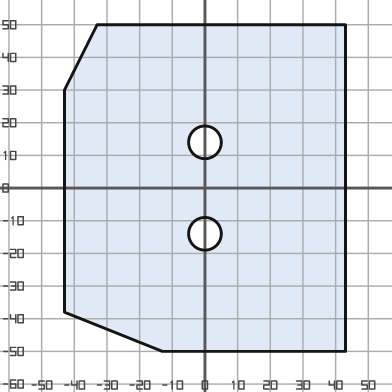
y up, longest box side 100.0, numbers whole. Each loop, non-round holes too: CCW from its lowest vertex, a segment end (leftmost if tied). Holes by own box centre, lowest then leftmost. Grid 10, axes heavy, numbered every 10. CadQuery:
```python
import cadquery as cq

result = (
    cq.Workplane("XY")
    .moveTo(-13.0, -50.0)
    .lineTo(43.0, -50.0)
    .lineTo(43.0, 50.0)
    .lineTo(-33.0, 50.0)
    .lineTo(-43.0, 30.0)
    .lineTo(-43.0, -38.0)
    .close()
    .moveTo(0.0, -14.0)
    .circle(5.0)
    .moveTo(0.0, 14.0)
    .circle(5.0)
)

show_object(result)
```